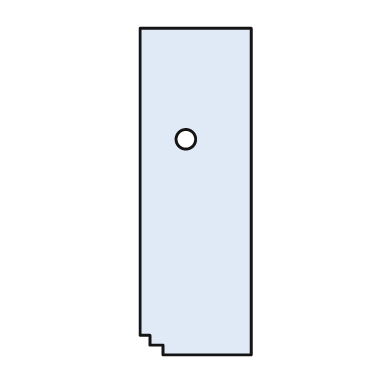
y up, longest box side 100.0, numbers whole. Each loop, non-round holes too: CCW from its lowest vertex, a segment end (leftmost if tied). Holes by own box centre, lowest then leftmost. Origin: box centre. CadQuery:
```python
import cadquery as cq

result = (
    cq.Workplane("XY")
    .moveTo(-10.0, -50.0)
    .lineTo(17.0, -50.0)
    .lineTo(17.0, 50.0)
    .lineTo(-17.0, 50.0)
    .lineTo(-17.0, -44.0)
    .lineTo(-14.0, -44.0)
    .lineTo(-14.0, -47.0)
    .lineTo(-10.0, -47.0)
    .close()
    .moveTo(-3.0, 16.0)
    .circle(3.0)
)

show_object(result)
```